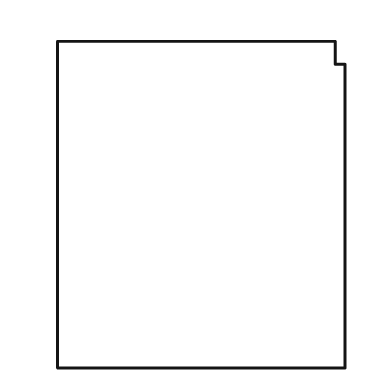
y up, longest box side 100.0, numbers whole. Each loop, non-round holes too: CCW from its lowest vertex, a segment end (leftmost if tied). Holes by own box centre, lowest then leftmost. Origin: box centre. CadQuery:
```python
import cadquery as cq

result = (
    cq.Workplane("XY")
    .moveTo(-44.0, -50.0)
    .lineTo(44.0, -50.0)
    .lineTo(44.0, 43.0)
    .lineTo(41.0, 43.0)
    .lineTo(41.0, 50.0)
    .lineTo(-44.0, 50.0)
    .close()
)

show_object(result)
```